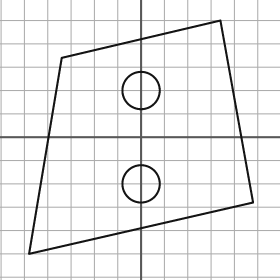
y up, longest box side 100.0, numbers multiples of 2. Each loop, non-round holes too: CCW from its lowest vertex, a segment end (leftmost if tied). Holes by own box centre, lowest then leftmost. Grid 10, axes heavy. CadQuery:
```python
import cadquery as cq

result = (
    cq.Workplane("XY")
    .moveTo(-48.0, -50.0)
    .lineTo(48.0, -28.0)
    .lineTo(34.0, 50.0)
    .lineTo(-34.0, 34.0)
    .close()
    .moveTo(0.0, -20.0)
    .circle(8.0)
    .moveTo(0.0, 20.0)
    .circle(8.0)
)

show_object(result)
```